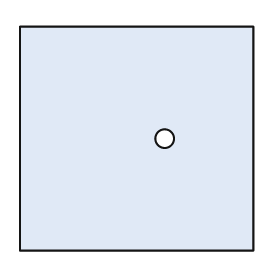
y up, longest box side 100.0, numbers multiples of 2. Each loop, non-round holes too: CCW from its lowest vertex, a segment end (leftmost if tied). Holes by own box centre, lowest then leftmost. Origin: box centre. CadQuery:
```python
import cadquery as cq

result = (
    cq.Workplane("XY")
    .moveTo(-50.0, -48.0)
    .lineTo(50.0, -48.0)
    .lineTo(50.0, 48.0)
    .lineTo(-50.0, 48.0)
    .close()
    .moveTo(12.0, 0.0)
    .circle(4.0)
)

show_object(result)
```